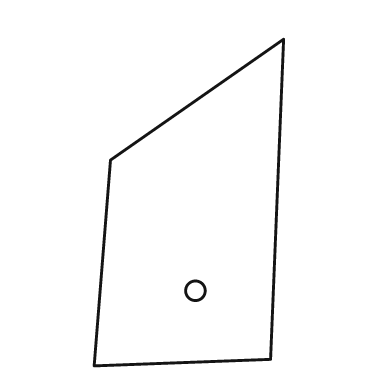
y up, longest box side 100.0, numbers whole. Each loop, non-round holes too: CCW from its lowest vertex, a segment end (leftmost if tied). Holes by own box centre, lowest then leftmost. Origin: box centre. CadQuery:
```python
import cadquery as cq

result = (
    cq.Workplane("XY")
    .moveTo(-29.0, -50.0)
    .lineTo(25.0, -48.0)
    .lineTo(29.0, 50.0)
    .lineTo(-24.0, 13.0)
    .close()
    .moveTo(2.0, -27.0)
    .circle(3.0)
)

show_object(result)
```